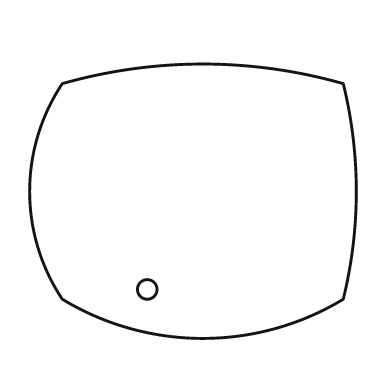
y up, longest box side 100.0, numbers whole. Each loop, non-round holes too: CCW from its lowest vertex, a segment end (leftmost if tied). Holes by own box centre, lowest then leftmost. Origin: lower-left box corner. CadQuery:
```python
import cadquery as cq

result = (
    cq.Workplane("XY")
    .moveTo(10.0, 12.0)
    .threePointArc((53.0, 0.0), (96.0, 12.0))
    .threePointArc((100.0, 45.0), (96.0, 78.0))
    .threePointArc((53.0, 84.0), (10.0, 78.0))
    .threePointArc((0.0, 45.0), (10.0, 12.0))
    .close()
    .moveTo(36.0, 15.0)
    .circle(3.0)
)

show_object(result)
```